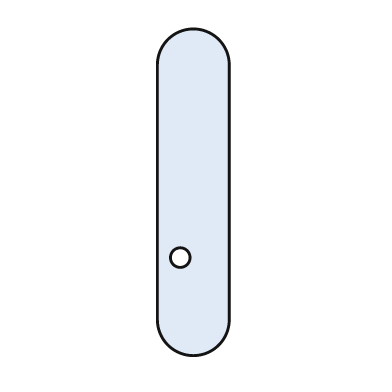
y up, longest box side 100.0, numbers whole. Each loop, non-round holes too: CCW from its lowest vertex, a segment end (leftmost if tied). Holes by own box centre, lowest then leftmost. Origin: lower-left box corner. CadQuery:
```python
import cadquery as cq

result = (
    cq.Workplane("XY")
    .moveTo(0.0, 11.0)
    .threePointArc((11.0, 0.0), (22.0, 11.0))
    .lineTo(22.0, 89.0)
    .threePointArc((11.0, 100.0), (0.0, 89.0))
    .close()
    .moveTo(7.0, 30.0)
    .circle(3.0)
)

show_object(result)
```